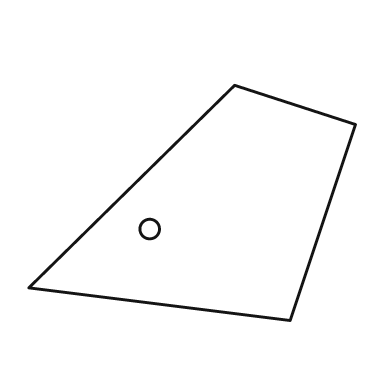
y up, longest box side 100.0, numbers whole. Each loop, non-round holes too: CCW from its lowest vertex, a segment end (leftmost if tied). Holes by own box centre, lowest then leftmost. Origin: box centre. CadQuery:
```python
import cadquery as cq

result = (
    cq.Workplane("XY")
    .moveTo(30.0, -36.0)
    .lineTo(50.0, 24.0)
    .lineTo(13.0, 36.0)
    .lineTo(-50.0, -26.0)
    .close()
    .moveTo(-13.0, -8.0)
    .circle(3.0)
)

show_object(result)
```